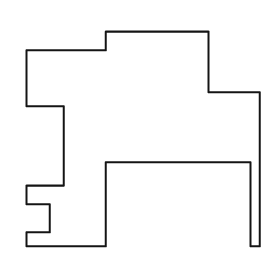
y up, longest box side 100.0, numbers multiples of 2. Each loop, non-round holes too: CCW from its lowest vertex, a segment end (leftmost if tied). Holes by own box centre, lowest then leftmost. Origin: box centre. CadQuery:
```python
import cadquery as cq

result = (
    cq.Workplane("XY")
    .moveTo(-50.0, -46.0)
    .lineTo(-16.0, -46.0)
    .lineTo(-16.0, -10.0)
    .lineTo(46.0, -10.0)
    .lineTo(46.0, -46.0)
    .lineTo(50.0, -46.0)
    .lineTo(50.0, 20.0)
    .lineTo(28.0, 20.0)
    .lineTo(28.0, 46.0)
    .lineTo(-16.0, 46.0)
    .lineTo(-16.0, 38.0)
    .lineTo(-50.0, 38.0)
    .lineTo(-50.0, 14.0)
    .lineTo(-34.0, 14.0)
    .lineTo(-34.0, -20.0)
    .lineTo(-50.0, -20.0)
    .lineTo(-50.0, -28.0)
    .lineTo(-40.0, -28.0)
    .lineTo(-40.0, -40.0)
    .lineTo(-50.0, -40.0)
    .close()
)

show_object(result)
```